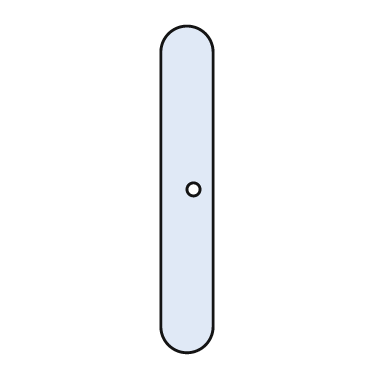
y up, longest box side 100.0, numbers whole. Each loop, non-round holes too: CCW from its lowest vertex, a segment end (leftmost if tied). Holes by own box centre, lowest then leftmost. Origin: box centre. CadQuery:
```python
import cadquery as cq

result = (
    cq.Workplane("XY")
    .moveTo(-8.0, -42.0)
    .threePointArc((0.0, -50.0), (8.0, -42.0))
    .lineTo(8.0, 42.0)
    .threePointArc((0.0, 50.0), (-8.0, 42.0))
    .close()
    .moveTo(2.0, 0.0)
    .circle(2.0)
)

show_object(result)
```